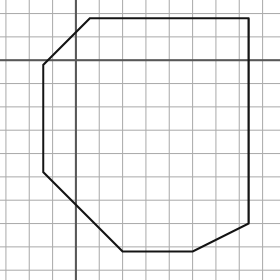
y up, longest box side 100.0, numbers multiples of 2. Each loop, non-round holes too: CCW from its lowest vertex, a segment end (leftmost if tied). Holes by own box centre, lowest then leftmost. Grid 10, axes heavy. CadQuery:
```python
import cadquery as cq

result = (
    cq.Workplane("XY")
    .moveTo(20.0, -82.0)
    .lineTo(50.0, -82.0)
    .lineTo(74.0, -70.0)
    .lineTo(74.0, 18.0)
    .lineTo(6.0, 18.0)
    .lineTo(-14.0, -2.0)
    .lineTo(-14.0, -48.0)
    .close()
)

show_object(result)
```